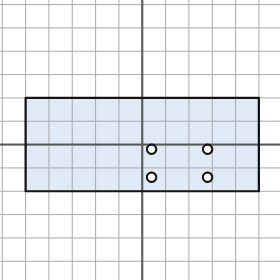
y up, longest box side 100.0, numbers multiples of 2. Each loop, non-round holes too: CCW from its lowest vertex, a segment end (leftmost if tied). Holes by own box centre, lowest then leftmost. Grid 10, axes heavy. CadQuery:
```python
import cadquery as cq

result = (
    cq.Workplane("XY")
    .moveTo(-50.0, -20.0)
    .lineTo(50.0, -20.0)
    .lineTo(50.0, 20.0)
    .lineTo(-50.0, 20.0)
    .close()
    .moveTo(4.0, -14.0)
    .circle(2.0)
    .moveTo(28.0, -14.0)
    .circle(2.0)
    .moveTo(4.0, -2.0)
    .circle(2.0)
    .moveTo(28.0, -2.0)
    .circle(2.0)
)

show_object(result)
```